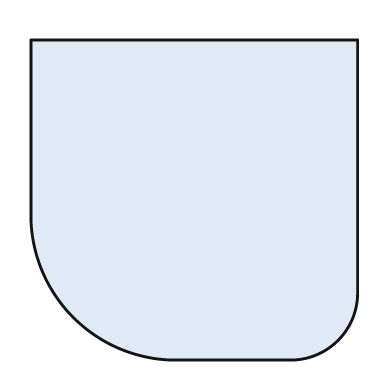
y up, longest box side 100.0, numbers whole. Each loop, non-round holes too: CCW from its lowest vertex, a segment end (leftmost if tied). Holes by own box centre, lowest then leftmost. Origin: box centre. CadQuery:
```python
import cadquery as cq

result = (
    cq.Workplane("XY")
    .moveTo(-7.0, -49.0)
    .lineTo(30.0, -49.0)
    .threePointArc((44.0, -43.0), (50.0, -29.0))
    .lineTo(50.0, 49.0)
    .lineTo(-50.0, 49.0)
    .lineTo(-50.0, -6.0)
    .threePointArc((-37.0, -36.0), (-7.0, -49.0))
    .close()
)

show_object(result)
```